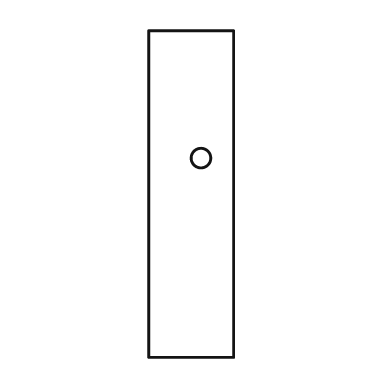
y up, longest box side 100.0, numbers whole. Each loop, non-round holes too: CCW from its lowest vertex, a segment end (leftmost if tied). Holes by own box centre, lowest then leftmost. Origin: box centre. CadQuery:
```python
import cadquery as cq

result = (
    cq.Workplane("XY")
    .moveTo(-13.0, -50.0)
    .lineTo(13.0, -50.0)
    .lineTo(13.0, 50.0)
    .lineTo(-13.0, 50.0)
    .close()
    .moveTo(3.0, 11.0)
    .circle(3.0)
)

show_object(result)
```